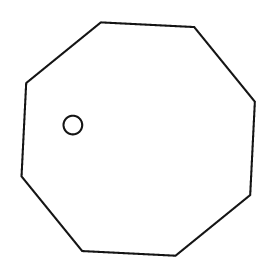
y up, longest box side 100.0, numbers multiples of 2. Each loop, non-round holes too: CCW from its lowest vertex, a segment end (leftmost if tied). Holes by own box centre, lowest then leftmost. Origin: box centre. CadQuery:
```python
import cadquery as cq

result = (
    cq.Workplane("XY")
    .moveTo(16.0, -50.0)
    .lineTo(48.0, -24.0)
    .lineTo(50.0, 16.0)
    .lineTo(24.0, 48.0)
    .lineTo(-16.0, 50.0)
    .lineTo(-48.0, 24.0)
    .lineTo(-50.0, -16.0)
    .lineTo(-24.0, -48.0)
    .close()
    .moveTo(-28.0, 6.0)
    .circle(4.0)
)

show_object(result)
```